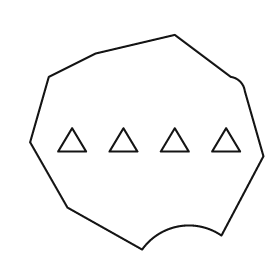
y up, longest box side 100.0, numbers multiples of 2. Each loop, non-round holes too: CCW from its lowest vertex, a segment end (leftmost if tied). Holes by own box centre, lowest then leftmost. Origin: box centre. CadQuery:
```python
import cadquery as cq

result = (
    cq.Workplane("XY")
    .moveTo(-2.0, -46.0)
    .threePointArc((14.0, -36.0), (32.0, -40.0))
    .lineTo(50.0, -6.0)
    .lineTo(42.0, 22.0)
    .threePointArc((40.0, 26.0), (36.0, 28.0))
    .lineTo(12.0, 46.0)
    .lineTo(-22.0, 38.0)
    .lineTo(-42.0, 28.0)
    .lineTo(-50.0, 0.0)
    .lineTo(-34.0, -28.0)
    .close()
    .moveTo(-38.0, -4.0)
    .lineTo(-26.0, -4.0)
    .lineTo(-32.0, 6.0)
    .close()
    .moveTo(-16.0, -4.0)
    .lineTo(-4.0, -4.0)
    .lineTo(-10.0, 6.0)
    .close()
    .moveTo(6.0, -4.0)
    .lineTo(18.0, -4.0)
    .lineTo(12.0, 6.0)
    .close()
    .moveTo(28.0, -4.0)
    .lineTo(40.0, -4.0)
    .lineTo(34.0, 6.0)
    .close()
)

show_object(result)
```